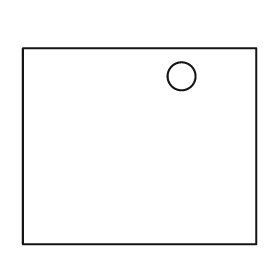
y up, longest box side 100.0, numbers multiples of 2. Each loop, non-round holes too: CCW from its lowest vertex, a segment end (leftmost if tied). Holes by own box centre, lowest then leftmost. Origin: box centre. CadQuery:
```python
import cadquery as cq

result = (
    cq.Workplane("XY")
    .moveTo(-50.0, -42.0)
    .lineTo(50.0, -42.0)
    .lineTo(50.0, 42.0)
    .lineTo(-50.0, 42.0)
    .close()
    .moveTo(18.0, 30.0)
    .circle(6.0)
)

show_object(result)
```